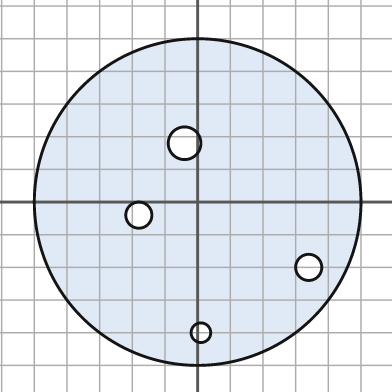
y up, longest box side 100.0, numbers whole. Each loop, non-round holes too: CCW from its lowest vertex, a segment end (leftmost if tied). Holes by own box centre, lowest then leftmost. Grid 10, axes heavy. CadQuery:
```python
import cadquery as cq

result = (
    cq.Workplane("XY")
    .moveTo(0.0, 0.0)
    .circle(50.0)
    .moveTo(1.0, -40.0)
    .circle(3.0)
    .moveTo(34.0, -20.0)
    .circle(4.0)
    .moveTo(-18.0, -4.0)
    .circle(4.0)
    .moveTo(-4.0, 18.0)
    .circle(5.0)
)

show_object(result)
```